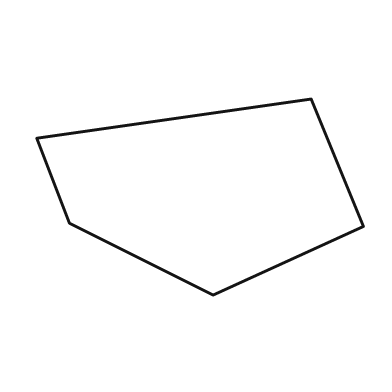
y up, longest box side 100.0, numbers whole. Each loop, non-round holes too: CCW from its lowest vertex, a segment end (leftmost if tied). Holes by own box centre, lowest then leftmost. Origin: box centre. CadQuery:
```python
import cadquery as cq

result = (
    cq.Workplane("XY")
    .moveTo(4.0, -30.0)
    .lineTo(50.0, -9.0)
    .lineTo(34.0, 30.0)
    .lineTo(-50.0, 18.0)
    .lineTo(-40.0, -8.0)
    .close()
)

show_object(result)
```